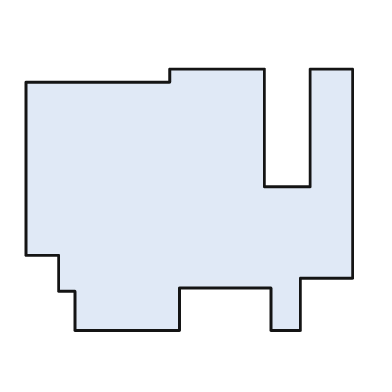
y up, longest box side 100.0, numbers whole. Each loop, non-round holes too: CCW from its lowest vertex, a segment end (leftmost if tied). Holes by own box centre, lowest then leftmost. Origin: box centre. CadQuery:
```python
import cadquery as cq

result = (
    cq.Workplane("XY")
    .moveTo(-35.0, -40.0)
    .lineTo(-3.0, -40.0)
    .lineTo(-3.0, -27.0)
    .lineTo(25.0, -27.0)
    .lineTo(25.0, -40.0)
    .lineTo(34.0, -40.0)
    .lineTo(34.0, -24.0)
    .lineTo(50.0, -24.0)
    .lineTo(50.0, 40.0)
    .lineTo(37.0, 40.0)
    .lineTo(37.0, 4.0)
    .lineTo(23.0, 4.0)
    .lineTo(23.0, 40.0)
    .lineTo(-6.0, 40.0)
    .lineTo(-6.0, 36.0)
    .lineTo(-50.0, 36.0)
    .lineTo(-50.0, -17.0)
    .lineTo(-40.0, -17.0)
    .lineTo(-40.0, -28.0)
    .lineTo(-35.0, -28.0)
    .close()
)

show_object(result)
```